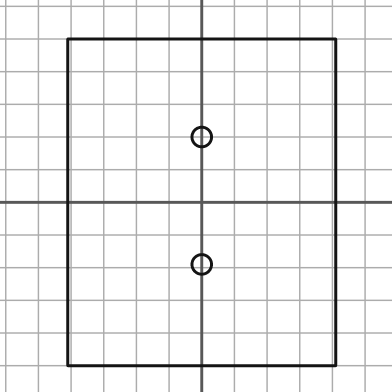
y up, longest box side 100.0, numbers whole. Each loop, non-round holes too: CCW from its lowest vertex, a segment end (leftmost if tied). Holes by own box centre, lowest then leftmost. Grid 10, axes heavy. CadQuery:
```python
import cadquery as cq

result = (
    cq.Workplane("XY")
    .moveTo(-41.0, -50.0)
    .lineTo(41.0, -50.0)
    .lineTo(41.0, 50.0)
    .lineTo(-41.0, 50.0)
    .close()
    .moveTo(0.0, -19.0)
    .circle(3.0)
    .moveTo(0.0, 20.0)
    .circle(3.0)
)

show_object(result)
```